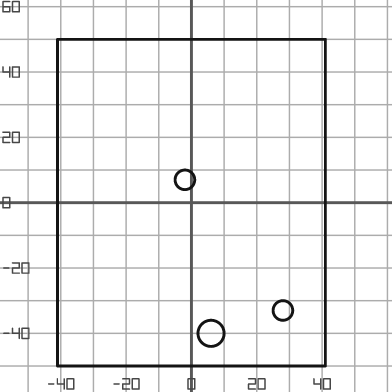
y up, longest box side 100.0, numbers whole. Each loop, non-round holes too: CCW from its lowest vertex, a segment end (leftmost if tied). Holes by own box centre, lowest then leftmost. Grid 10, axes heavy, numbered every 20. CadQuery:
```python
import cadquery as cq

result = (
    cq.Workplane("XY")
    .moveTo(-41.0, -50.0)
    .lineTo(41.0, -50.0)
    .lineTo(41.0, 50.0)
    .lineTo(-41.0, 50.0)
    .close()
    .moveTo(6.0, -40.0)
    .circle(4.0)
    .moveTo(28.0, -33.0)
    .circle(3.0)
    .moveTo(-2.0, 7.0)
    .circle(3.0)
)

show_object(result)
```